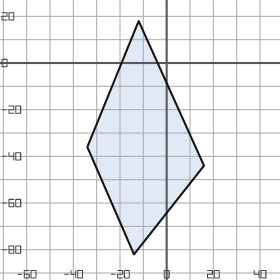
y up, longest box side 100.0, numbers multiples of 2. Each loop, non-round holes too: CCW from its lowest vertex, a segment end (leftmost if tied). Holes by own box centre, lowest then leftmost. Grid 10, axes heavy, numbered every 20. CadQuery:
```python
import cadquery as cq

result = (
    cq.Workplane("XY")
    .moveTo(-14.0, -82.0)
    .lineTo(16.0, -44.0)
    .lineTo(-12.0, 18.0)
    .lineTo(-34.0, -36.0)
    .close()
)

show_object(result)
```